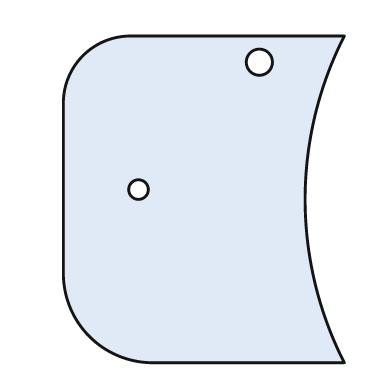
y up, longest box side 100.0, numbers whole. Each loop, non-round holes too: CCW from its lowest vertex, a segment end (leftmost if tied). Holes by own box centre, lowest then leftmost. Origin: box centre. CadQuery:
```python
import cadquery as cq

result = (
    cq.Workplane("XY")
    .moveTo(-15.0, -50.0)
    .lineTo(43.0, -50.0)
    .threePointArc((31.0, 0.0), (43.0, 50.0))
    .lineTo(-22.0, 50.0)
    .threePointArc((-37.0, 44.0), (-43.0, 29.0))
    .lineTo(-43.0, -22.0)
    .threePointArc((-35.0, -42.0), (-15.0, -50.0))
    .close()
    .moveTo(-20.0, 3.0)
    .circle(3.0)
    .moveTo(17.0, 42.0)
    .circle(4.0)
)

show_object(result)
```